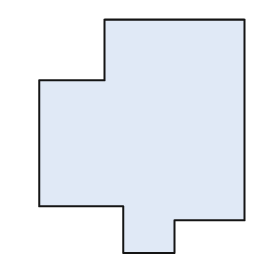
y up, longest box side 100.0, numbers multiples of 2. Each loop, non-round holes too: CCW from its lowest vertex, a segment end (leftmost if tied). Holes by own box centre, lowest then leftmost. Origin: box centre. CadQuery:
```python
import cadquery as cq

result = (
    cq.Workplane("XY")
    .moveTo(-8.0, -50.0)
    .lineTo(14.0, -50.0)
    .lineTo(14.0, -36.0)
    .lineTo(44.0, -36.0)
    .lineTo(44.0, 50.0)
    .lineTo(-16.0, 50.0)
    .lineTo(-16.0, 24.0)
    .lineTo(-44.0, 24.0)
    .lineTo(-44.0, -30.0)
    .lineTo(-8.0, -30.0)
    .close()
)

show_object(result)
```